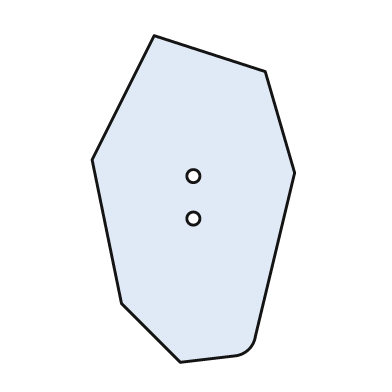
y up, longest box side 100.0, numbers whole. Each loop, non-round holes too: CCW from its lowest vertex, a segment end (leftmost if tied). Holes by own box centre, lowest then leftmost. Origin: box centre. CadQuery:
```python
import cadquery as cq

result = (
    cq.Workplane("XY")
    .moveTo(-4.0, -50.0)
    .lineTo(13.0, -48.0)
    .threePointArc((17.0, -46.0), (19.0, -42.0))
    .lineTo(31.0, 8.0)
    .lineTo(22.0, 39.0)
    .lineTo(-12.0, 50.0)
    .lineTo(-31.0, 12.0)
    .lineTo(-22.0, -32.0)
    .close()
    .moveTo(0.0, -6.0)
    .circle(2.0)
    .moveTo(0.0, 7.0)
    .circle(2.0)
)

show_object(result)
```